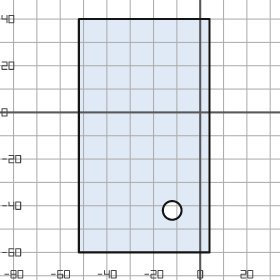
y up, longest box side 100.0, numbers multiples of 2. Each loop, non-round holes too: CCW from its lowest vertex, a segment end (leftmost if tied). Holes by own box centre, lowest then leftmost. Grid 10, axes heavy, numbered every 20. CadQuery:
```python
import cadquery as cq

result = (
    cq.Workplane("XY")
    .moveTo(-52.0, -60.0)
    .lineTo(4.0, -60.0)
    .lineTo(4.0, 40.0)
    .lineTo(-52.0, 40.0)
    .close()
    .moveTo(-12.0, -42.0)
    .circle(4.0)
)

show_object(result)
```